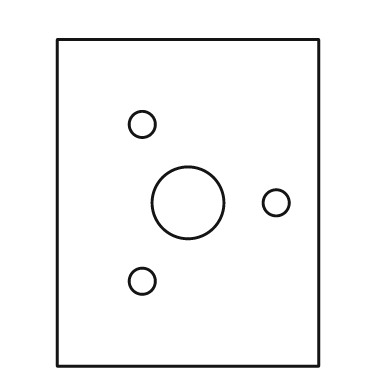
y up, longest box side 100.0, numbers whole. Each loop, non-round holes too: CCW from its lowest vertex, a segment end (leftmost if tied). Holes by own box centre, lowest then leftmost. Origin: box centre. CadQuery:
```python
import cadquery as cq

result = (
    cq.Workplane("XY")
    .moveTo(-40.0, -50.0)
    .lineTo(40.0, -50.0)
    .lineTo(40.0, 50.0)
    .lineTo(-40.0, 50.0)
    .close()
    .moveTo(-14.0, -24.0)
    .circle(4.0)
    .moveTo(0.0, 0.0)
    .circle(11.0)
    .moveTo(27.0, 0.0)
    .circle(4.0)
    .moveTo(-14.0, 24.0)
    .circle(4.0)
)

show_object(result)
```